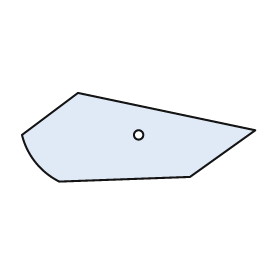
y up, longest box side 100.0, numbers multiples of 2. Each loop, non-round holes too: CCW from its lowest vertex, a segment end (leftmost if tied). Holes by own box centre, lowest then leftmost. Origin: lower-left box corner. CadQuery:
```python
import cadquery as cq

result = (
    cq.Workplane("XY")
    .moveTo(16.0, 0.0)
    .lineTo(72.0, 2.0)
    .lineTo(100.0, 22.0)
    .lineTo(24.0, 38.0)
    .lineTo(0.0, 20.0)
    .threePointArc((6.0, 8.0), (16.0, 0.0))
    .close()
    .moveTo(50.0, 20.0)
    .circle(2.0)
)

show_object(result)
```